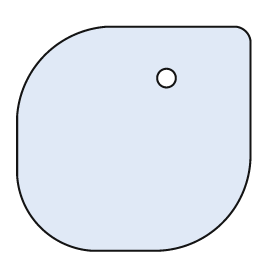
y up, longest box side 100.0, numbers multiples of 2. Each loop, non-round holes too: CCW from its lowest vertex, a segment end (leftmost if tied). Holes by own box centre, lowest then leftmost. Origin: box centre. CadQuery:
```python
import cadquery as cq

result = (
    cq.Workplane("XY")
    .moveTo(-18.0, -48.0)
    .lineTo(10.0, -48.0)
    .threePointArc((38.0, -36.0), (50.0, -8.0))
    .lineTo(50.0, 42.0)
    .threePointArc((48.0, 46.0), (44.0, 48.0))
    .lineTo(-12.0, 48.0)
    .threePointArc((-38.0, 36.0), (-50.0, 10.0))
    .lineTo(-50.0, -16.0)
    .threePointArc((-40.0, -38.0), (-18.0, -48.0))
    .close()
    .moveTo(14.0, 26.0)
    .circle(4.0)
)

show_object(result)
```